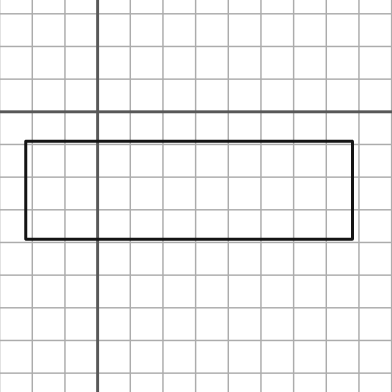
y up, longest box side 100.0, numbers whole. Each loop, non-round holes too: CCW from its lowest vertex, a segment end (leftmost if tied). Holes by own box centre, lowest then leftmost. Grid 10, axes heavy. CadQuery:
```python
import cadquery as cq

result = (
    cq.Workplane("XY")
    .moveTo(-22.0, -39.0)
    .lineTo(78.0, -39.0)
    .lineTo(78.0, -9.0)
    .lineTo(-22.0, -9.0)
    .close()
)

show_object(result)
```